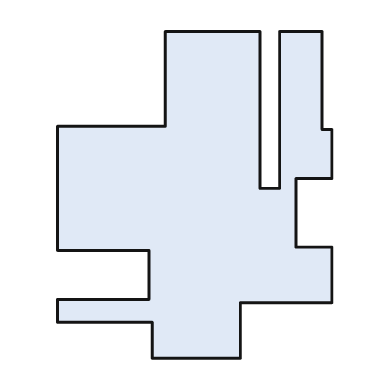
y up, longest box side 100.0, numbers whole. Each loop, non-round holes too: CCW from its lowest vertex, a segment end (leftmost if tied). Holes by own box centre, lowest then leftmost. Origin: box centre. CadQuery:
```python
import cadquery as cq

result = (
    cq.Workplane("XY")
    .moveTo(-13.0, -50.0)
    .lineTo(14.0, -50.0)
    .lineTo(14.0, -33.0)
    .lineTo(42.0, -33.0)
    .lineTo(42.0, -16.0)
    .lineTo(31.0, -16.0)
    .lineTo(31.0, 5.0)
    .lineTo(42.0, 5.0)
    .lineTo(42.0, 20.0)
    .lineTo(39.0, 20.0)
    .lineTo(39.0, 50.0)
    .lineTo(26.0, 50.0)
    .lineTo(26.0, 2.0)
    .lineTo(20.0, 2.0)
    .lineTo(20.0, 50.0)
    .lineTo(-9.0, 50.0)
    .lineTo(-9.0, 21.0)
    .lineTo(-42.0, 21.0)
    .lineTo(-42.0, -17.0)
    .lineTo(-14.0, -17.0)
    .lineTo(-14.0, -32.0)
    .lineTo(-42.0, -32.0)
    .lineTo(-42.0, -39.0)
    .lineTo(-13.0, -39.0)
    .close()
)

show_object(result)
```